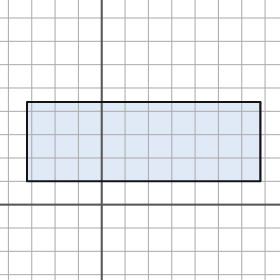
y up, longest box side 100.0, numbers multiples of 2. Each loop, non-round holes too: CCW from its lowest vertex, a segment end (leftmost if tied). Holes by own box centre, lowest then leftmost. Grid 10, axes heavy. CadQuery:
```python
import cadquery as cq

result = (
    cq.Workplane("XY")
    .moveTo(-32.0, 10.0)
    .lineTo(68.0, 10.0)
    .lineTo(68.0, 44.0)
    .lineTo(-32.0, 44.0)
    .close()
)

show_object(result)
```